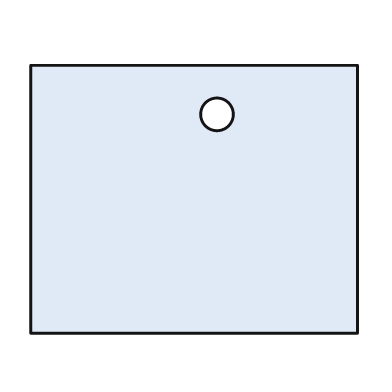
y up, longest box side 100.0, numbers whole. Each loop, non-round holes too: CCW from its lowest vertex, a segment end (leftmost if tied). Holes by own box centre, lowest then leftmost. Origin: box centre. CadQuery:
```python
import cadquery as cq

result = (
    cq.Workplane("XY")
    .moveTo(-50.0, -41.0)
    .lineTo(50.0, -41.0)
    .lineTo(50.0, 41.0)
    .lineTo(-50.0, 41.0)
    .close()
    .moveTo(7.0, 26.0)
    .circle(5.0)
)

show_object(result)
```